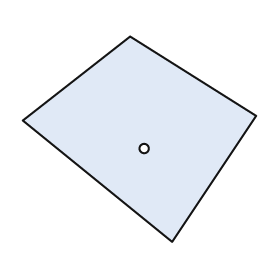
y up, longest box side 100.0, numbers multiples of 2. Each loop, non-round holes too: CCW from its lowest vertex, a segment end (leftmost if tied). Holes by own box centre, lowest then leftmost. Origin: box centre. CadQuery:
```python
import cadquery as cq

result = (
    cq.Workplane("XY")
    .moveTo(14.0, -44.0)
    .lineTo(50.0, 10.0)
    .lineTo(-4.0, 44.0)
    .lineTo(-50.0, 8.0)
    .close()
    .moveTo(2.0, -4.0)
    .circle(2.0)
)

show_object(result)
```